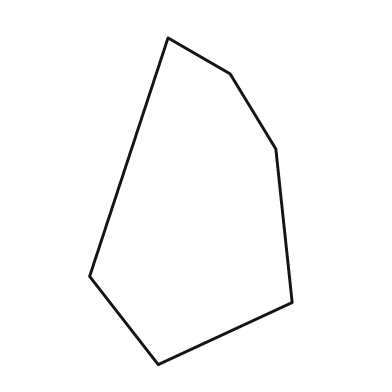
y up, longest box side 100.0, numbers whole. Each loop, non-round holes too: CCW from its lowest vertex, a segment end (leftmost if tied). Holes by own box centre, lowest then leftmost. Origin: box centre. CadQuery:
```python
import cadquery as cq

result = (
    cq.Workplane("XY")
    .moveTo(-10.0, -50.0)
    .lineTo(31.0, -31.0)
    .lineTo(26.0, 16.0)
    .lineTo(12.0, 39.0)
    .lineTo(-7.0, 50.0)
    .lineTo(-31.0, -23.0)
    .close()
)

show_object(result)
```